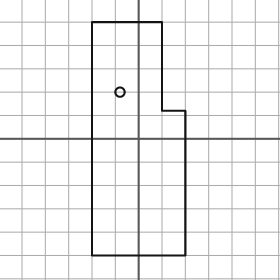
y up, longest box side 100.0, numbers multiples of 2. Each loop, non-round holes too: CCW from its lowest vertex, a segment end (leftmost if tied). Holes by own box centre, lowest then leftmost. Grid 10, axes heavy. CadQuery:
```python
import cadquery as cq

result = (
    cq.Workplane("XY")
    .moveTo(-20.0, -50.0)
    .lineTo(20.0, -50.0)
    .lineTo(20.0, 12.0)
    .lineTo(10.0, 12.0)
    .lineTo(10.0, 50.0)
    .lineTo(-20.0, 50.0)
    .close()
    .moveTo(-8.0, 20.0)
    .circle(2.0)
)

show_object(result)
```